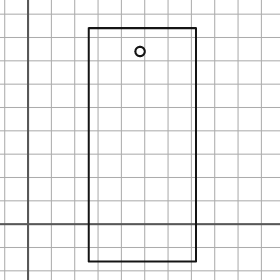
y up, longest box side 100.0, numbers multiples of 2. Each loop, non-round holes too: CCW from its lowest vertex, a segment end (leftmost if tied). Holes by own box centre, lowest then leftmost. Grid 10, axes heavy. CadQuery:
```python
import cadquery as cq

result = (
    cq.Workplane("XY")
    .moveTo(26.0, -16.0)
    .lineTo(72.0, -16.0)
    .lineTo(72.0, 84.0)
    .lineTo(26.0, 84.0)
    .close()
    .moveTo(48.0, 74.0)
    .circle(2.0)
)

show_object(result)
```